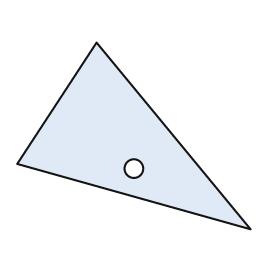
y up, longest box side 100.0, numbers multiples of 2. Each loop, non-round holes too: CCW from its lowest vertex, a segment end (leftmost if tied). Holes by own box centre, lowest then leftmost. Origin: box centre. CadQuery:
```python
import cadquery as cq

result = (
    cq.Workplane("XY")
    .moveTo(50.0, -40.0)
    .lineTo(-16.0, 40.0)
    .lineTo(-50.0, -12.0)
    .close()
    .moveTo(0.0, -14.0)
    .circle(4.0)
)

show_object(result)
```